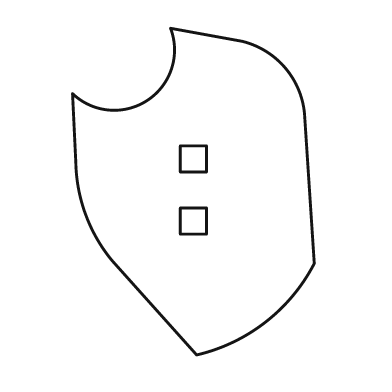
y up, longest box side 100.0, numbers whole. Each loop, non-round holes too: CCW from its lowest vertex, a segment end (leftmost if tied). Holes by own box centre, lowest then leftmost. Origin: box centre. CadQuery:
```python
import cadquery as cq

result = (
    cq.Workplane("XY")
    .moveTo(1.0, -50.0)
    .threePointArc((22.0, -40.0), (37.0, -22.0))
    .lineTo(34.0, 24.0)
    .threePointArc((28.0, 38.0), (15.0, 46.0))
    .lineTo(-7.0, 50.0)
    .threePointArc((-14.0, 28.0), (-37.0, 30.0))
    .lineTo(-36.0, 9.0)
    .threePointArc((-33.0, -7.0), (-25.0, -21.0))
    .close()
    .moveTo(-4.0, -13.0)
    .lineTo(4.0, -13.0)
    .lineTo(4.0, -5.0)
    .lineTo(-4.0, -5.0)
    .close()
    .moveTo(-4.0, 6.0)
    .lineTo(4.0, 6.0)
    .lineTo(4.0, 14.0)
    .lineTo(-4.0, 14.0)
    .close()
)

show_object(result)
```